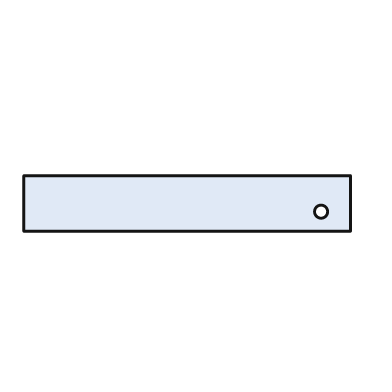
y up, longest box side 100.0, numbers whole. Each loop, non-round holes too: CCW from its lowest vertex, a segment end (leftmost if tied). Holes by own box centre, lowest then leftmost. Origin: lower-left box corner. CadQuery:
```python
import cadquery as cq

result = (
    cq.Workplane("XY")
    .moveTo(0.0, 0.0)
    .lineTo(100.0, 0.0)
    .lineTo(100.0, 17.0)
    .lineTo(0.0, 17.0)
    .close()
    .moveTo(91.0, 6.0)
    .circle(2.0)
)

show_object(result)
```